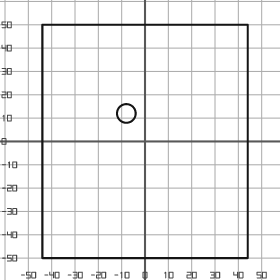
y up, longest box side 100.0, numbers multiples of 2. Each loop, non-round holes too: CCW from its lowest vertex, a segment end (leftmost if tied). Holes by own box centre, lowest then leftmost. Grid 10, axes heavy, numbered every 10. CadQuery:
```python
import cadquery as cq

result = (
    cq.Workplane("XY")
    .moveTo(-44.0, -50.0)
    .lineTo(44.0, -50.0)
    .lineTo(44.0, 50.0)
    .lineTo(-44.0, 50.0)
    .close()
    .moveTo(-8.0, 12.0)
    .circle(4.0)
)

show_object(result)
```